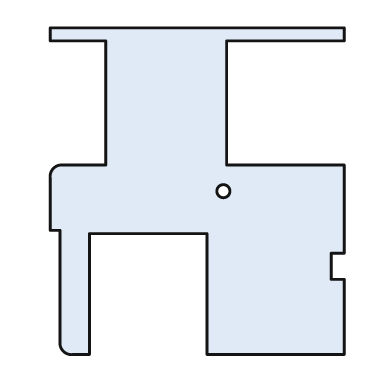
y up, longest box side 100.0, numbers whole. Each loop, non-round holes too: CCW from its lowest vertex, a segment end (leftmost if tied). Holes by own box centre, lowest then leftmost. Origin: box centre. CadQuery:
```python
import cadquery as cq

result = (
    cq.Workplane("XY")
    .moveTo(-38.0, -50.0)
    .lineTo(-33.0, -50.0)
    .lineTo(-33.0, -13.0)
    .lineTo(3.0, -13.0)
    .lineTo(3.0, -50.0)
    .lineTo(45.0, -50.0)
    .lineTo(45.0, -27.0)
    .lineTo(41.0, -27.0)
    .lineTo(41.0, -19.0)
    .lineTo(45.0, -19.0)
    .lineTo(45.0, 8.0)
    .lineTo(9.0, 8.0)
    .lineTo(9.0, 46.0)
    .lineTo(45.0, 46.0)
    .lineTo(45.0, 50.0)
    .lineTo(-45.0, 50.0)
    .lineTo(-45.0, 46.0)
    .lineTo(-28.0, 46.0)
    .lineTo(-28.0, 8.0)
    .lineTo(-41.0, 8.0)
    .threePointArc((-44.0, 7.0), (-45.0, 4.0))
    .lineTo(-45.0, -12.0)
    .lineTo(-42.0, -12.0)
    .lineTo(-42.0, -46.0)
    .threePointArc((-41.0, -49.0), (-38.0, -50.0))
    .close()
    .moveTo(8.0, 0.0)
    .circle(2.0)
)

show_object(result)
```